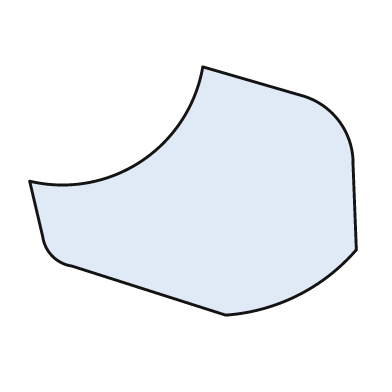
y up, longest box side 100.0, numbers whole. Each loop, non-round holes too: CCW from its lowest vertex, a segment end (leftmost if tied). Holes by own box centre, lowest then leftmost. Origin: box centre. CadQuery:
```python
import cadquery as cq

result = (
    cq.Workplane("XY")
    .moveTo(10.0, -38.0)
    .threePointArc((32.0, -32.0), (50.0, -18.0))
    .lineTo(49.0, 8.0)
    .threePointArc((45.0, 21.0), (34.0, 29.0))
    .lineTo(3.0, 38.0)
    .threePointArc((-16.0, 9.0), (-50.0, 3.0))
    .lineTo(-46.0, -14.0)
    .threePointArc((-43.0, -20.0), (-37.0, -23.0))
    .close()
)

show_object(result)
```